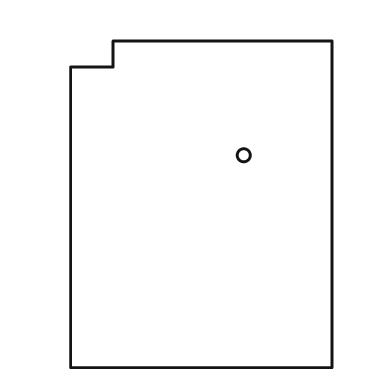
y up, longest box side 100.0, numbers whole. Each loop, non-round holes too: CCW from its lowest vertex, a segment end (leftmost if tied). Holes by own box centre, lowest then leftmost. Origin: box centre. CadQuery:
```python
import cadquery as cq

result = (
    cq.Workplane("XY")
    .moveTo(-40.0, -50.0)
    .lineTo(40.0, -50.0)
    .lineTo(40.0, 50.0)
    .lineTo(-27.0, 50.0)
    .lineTo(-27.0, 42.0)
    .lineTo(-40.0, 42.0)
    .close()
    .moveTo(13.0, 15.0)
    .circle(2.0)
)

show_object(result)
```